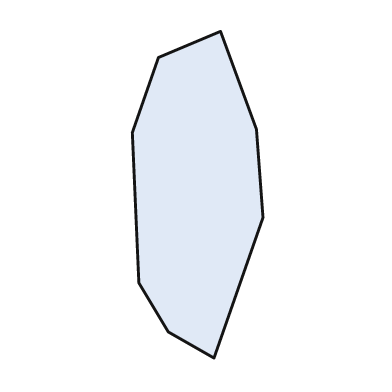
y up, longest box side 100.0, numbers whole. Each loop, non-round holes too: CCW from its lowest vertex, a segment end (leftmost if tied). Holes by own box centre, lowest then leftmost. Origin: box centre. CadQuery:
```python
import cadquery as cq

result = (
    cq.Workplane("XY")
    .moveTo(5.0, -50.0)
    .lineTo(20.0, -7.0)
    .lineTo(18.0, 20.0)
    .lineTo(7.0, 50.0)
    .lineTo(-12.0, 42.0)
    .lineTo(-20.0, 19.0)
    .lineTo(-18.0, -27.0)
    .lineTo(-9.0, -42.0)
    .close()
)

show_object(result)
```